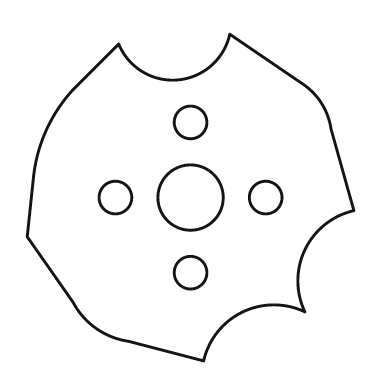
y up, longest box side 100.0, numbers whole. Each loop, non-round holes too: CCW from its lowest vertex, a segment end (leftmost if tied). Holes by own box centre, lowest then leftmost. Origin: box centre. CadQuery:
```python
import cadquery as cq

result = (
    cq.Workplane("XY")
    .moveTo(4.0, -50.0)
    .threePointArc((16.0, -35.0), (35.0, -35.0))
    .threePointArc((35.0, -16.0), (50.0, -4.0))
    .lineTo(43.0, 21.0)
    .threePointArc((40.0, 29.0), (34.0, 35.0))
    .lineTo(12.0, 50.0)
    .threePointArc((-4.0, 36.0), (-22.0, 47.0))
    .lineTo(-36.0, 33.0)
    .threePointArc((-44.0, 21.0), (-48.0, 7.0))
    .lineTo(-50.0, -12.0)
    .lineTo(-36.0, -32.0)
    .threePointArc((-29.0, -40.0), (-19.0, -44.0))
    .close()
    .moveTo(0.0, -23.0)
    .circle(5.0)
    .moveTo(-23.0, 0.0)
    .circle(5.0)
    .moveTo(0.0, 0.0)
    .circle(10.0)
    .moveTo(23.0, 0.0)
    .circle(5.0)
    .moveTo(0.0, 23.0)
    .circle(5.0)
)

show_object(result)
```